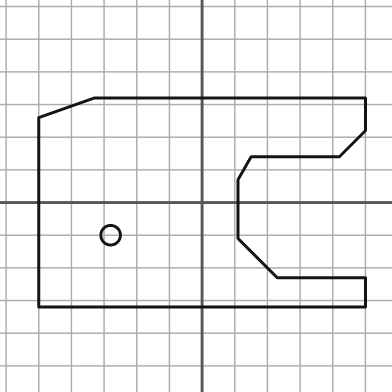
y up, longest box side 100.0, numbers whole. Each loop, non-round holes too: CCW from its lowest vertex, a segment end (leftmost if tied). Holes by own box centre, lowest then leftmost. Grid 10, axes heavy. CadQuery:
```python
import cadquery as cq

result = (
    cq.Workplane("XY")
    .moveTo(-50.0, -32.0)
    .lineTo(50.0, -32.0)
    .lineTo(50.0, -23.0)
    .lineTo(23.0, -23.0)
    .lineTo(11.0, -11.0)
    .lineTo(11.0, 7.0)
    .lineTo(15.0, 14.0)
    .lineTo(42.0, 14.0)
    .lineTo(50.0, 22.0)
    .lineTo(50.0, 32.0)
    .lineTo(-33.0, 32.0)
    .lineTo(-50.0, 26.0)
    .close()
    .moveTo(-28.0, -10.0)
    .circle(3.0)
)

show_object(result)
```